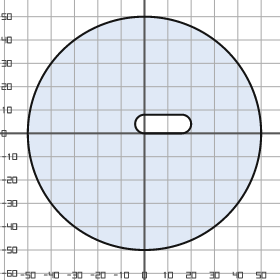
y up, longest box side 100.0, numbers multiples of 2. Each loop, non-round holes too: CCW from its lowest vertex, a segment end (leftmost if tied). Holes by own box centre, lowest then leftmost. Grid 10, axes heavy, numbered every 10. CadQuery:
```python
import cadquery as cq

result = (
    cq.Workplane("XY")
    .moveTo(0.0, 0.0)
    .circle(50.0)
    .moveTo(0.0, 0.0)
    .lineTo(16.0, 0.0)
    .threePointArc((20.0, 4.0), (16.0, 8.0))
    .lineTo(0.0, 8.0)
    .threePointArc((-4.0, 4.0), (0.0, 0.0))
    .close()
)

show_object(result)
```